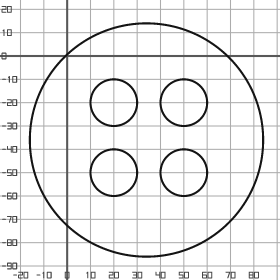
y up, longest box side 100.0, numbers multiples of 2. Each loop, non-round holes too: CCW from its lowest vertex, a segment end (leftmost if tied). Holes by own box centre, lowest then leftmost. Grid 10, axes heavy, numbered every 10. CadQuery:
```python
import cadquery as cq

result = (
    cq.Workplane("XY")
    .moveTo(34.0, -36.0)
    .circle(50.0)
    .moveTo(20.0, -50.0)
    .circle(10.0)
    .moveTo(50.0, -50.0)
    .circle(10.0)
    .moveTo(20.0, -20.0)
    .circle(10.0)
    .moveTo(50.0, -20.0)
    .circle(10.0)
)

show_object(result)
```